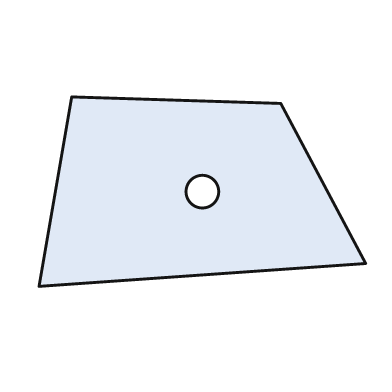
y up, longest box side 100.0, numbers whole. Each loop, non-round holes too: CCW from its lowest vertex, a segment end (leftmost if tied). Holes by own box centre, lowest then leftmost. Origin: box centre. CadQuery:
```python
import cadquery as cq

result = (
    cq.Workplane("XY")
    .moveTo(-50.0, -29.0)
    .lineTo(50.0, -22.0)
    .lineTo(24.0, 27.0)
    .lineTo(-40.0, 29.0)
    .close()
    .moveTo(0.0, 0.0)
    .circle(5.0)
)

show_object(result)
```